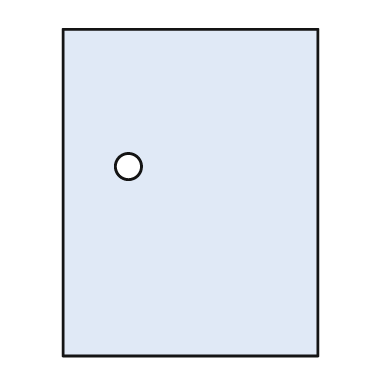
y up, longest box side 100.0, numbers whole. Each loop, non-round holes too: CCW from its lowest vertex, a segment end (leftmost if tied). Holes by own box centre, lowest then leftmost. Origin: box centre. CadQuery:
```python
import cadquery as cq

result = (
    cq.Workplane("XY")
    .moveTo(-39.0, -50.0)
    .lineTo(39.0, -50.0)
    .lineTo(39.0, 50.0)
    .lineTo(-39.0, 50.0)
    .close()
    .moveTo(-19.0, 8.0)
    .circle(4.0)
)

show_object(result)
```